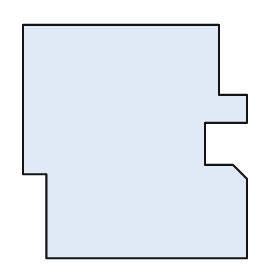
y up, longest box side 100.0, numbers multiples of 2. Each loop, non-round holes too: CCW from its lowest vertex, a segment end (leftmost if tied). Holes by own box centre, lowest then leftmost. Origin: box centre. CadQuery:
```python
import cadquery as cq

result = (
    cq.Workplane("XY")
    .moveTo(-38.0, -50.0)
    .lineTo(48.0, -50.0)
    .lineTo(48.0, -16.0)
    .lineTo(42.0, -10.0)
    .lineTo(30.0, -10.0)
    .lineTo(30.0, 8.0)
    .lineTo(48.0, 8.0)
    .lineTo(48.0, 20.0)
    .lineTo(36.0, 20.0)
    .lineTo(36.0, 50.0)
    .lineTo(-48.0, 50.0)
    .lineTo(-48.0, -14.0)
    .lineTo(-38.0, -14.0)
    .close()
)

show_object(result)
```